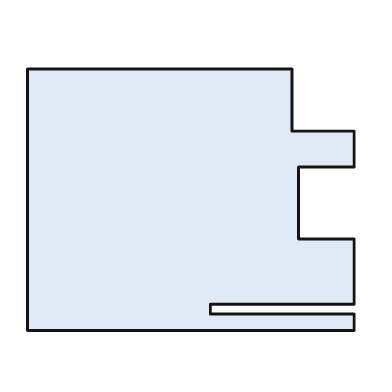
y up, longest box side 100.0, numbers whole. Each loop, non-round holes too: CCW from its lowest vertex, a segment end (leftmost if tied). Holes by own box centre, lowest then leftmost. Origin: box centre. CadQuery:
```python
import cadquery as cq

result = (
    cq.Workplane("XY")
    .moveTo(-50.0, -40.0)
    .lineTo(50.0, -40.0)
    .lineTo(50.0, -35.0)
    .lineTo(6.0, -35.0)
    .lineTo(6.0, -32.0)
    .lineTo(50.0, -32.0)
    .lineTo(50.0, -12.0)
    .lineTo(33.0, -12.0)
    .lineTo(33.0, 10.0)
    .lineTo(50.0, 10.0)
    .lineTo(50.0, 21.0)
    .lineTo(31.0, 21.0)
    .lineTo(31.0, 40.0)
    .lineTo(-50.0, 40.0)
    .close()
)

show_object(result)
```